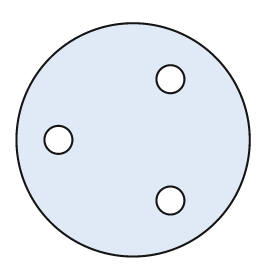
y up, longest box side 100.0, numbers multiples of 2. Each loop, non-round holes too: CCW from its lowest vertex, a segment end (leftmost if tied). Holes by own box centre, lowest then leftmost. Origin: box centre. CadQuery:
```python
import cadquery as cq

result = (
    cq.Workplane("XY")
    .moveTo(0.0, 0.0)
    .circle(50.0)
    .moveTo(16.0, -26.0)
    .circle(6.0)
    .moveTo(-32.0, 0.0)
    .circle(6.0)
    .moveTo(16.0, 26.0)
    .circle(6.0)
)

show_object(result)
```